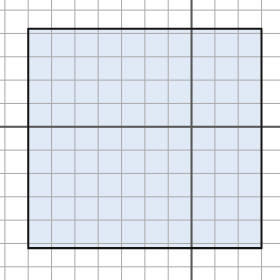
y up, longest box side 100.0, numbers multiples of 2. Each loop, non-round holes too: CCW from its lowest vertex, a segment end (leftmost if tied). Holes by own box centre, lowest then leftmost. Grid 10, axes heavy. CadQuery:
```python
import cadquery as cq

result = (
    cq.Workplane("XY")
    .moveTo(-70.0, -52.0)
    .lineTo(30.0, -52.0)
    .lineTo(30.0, 42.0)
    .lineTo(-70.0, 42.0)
    .close()
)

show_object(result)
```